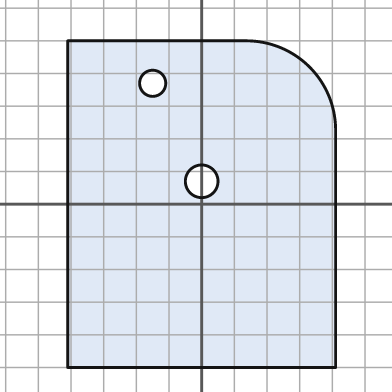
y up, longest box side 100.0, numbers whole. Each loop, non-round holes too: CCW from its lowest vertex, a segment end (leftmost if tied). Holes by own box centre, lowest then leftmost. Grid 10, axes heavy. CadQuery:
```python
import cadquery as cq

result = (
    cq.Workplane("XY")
    .moveTo(-41.0, -50.0)
    .lineTo(41.0, -50.0)
    .lineTo(41.0, 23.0)
    .threePointArc((33.0, 42.0), (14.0, 50.0))
    .lineTo(-41.0, 50.0)
    .close()
    .moveTo(0.0, 7.0)
    .circle(5.0)
    .moveTo(-15.0, 37.0)
    .circle(4.0)
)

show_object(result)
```